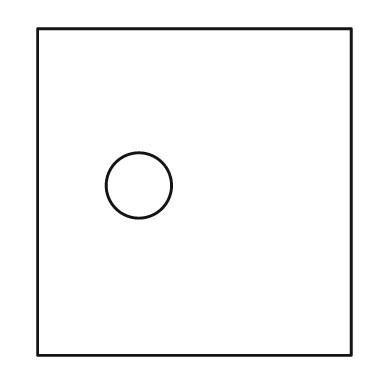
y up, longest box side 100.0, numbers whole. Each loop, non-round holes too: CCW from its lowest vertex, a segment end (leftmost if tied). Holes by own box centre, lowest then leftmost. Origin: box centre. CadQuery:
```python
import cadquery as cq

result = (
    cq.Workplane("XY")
    .moveTo(-48.0, -50.0)
    .lineTo(48.0, -50.0)
    .lineTo(48.0, 50.0)
    .lineTo(-48.0, 50.0)
    .close()
    .moveTo(-17.0, 2.0)
    .circle(10.0)
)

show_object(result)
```